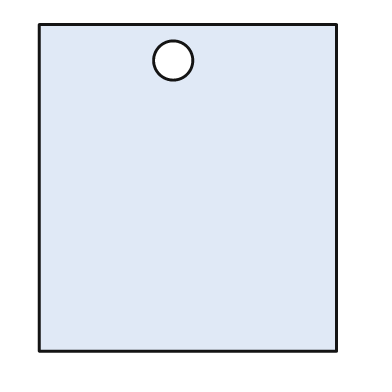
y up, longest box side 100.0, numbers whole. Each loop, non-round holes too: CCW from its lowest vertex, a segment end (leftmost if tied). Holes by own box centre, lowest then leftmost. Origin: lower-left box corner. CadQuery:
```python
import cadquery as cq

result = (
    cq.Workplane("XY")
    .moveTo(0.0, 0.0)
    .lineTo(91.0, 0.0)
    .lineTo(91.0, 100.0)
    .lineTo(0.0, 100.0)
    .close()
    .moveTo(41.0, 89.0)
    .circle(6.0)
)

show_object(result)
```